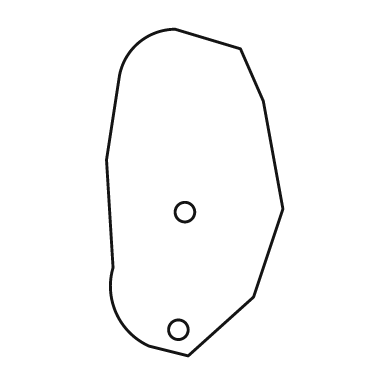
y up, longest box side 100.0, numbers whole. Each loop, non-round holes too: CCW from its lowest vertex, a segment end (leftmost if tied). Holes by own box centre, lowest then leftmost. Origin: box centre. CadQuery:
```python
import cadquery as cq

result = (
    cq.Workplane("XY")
    .moveTo(-2.0, -50.0)
    .lineTo(18.0, -32.0)
    .lineTo(27.0, -5.0)
    .lineTo(21.0, 28.0)
    .lineTo(14.0, 44.0)
    .lineTo(-6.0, 50.0)
    .threePointArc((-17.0, 46.0), (-23.0, 36.0))
    .lineTo(-27.0, 10.0)
    .lineTo(-25.0, -23.0)
    .threePointArc((-24.0, -37.0), (-14.0, -47.0))
    .close()
    .moveTo(-5.0, -42.0)
    .circle(3.0)
    .moveTo(-3.0, -6.0)
    .circle(3.0)
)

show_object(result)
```